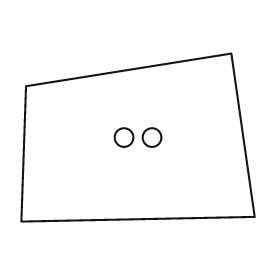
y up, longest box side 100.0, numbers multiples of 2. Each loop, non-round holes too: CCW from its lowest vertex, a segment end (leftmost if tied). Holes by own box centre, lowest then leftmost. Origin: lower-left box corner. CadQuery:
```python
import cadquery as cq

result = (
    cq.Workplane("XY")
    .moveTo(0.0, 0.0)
    .lineTo(100.0, 2.0)
    .lineTo(90.0, 72.0)
    .lineTo(2.0, 58.0)
    .close()
    .moveTo(44.0, 36.0)
    .circle(4.0)
    .moveTo(56.0, 36.0)
    .circle(4.0)
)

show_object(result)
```